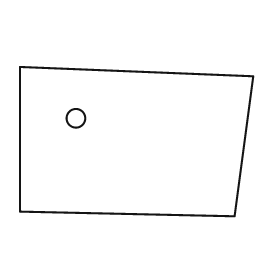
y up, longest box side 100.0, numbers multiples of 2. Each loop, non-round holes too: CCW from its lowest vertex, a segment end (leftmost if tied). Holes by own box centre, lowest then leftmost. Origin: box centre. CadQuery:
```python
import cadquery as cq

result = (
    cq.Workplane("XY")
    .moveTo(42.0, -32.0)
    .lineTo(50.0, 28.0)
    .lineTo(-50.0, 32.0)
    .lineTo(-50.0, -30.0)
    .close()
    .moveTo(-26.0, 10.0)
    .circle(4.0)
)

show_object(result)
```